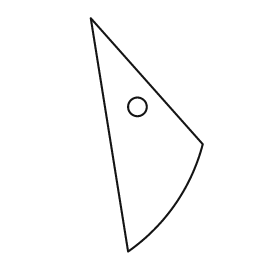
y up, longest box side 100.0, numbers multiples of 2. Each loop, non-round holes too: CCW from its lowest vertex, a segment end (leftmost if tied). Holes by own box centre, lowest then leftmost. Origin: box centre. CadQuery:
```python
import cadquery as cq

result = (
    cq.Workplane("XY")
    .moveTo(-8.0, -50.0)
    .threePointArc((12.0, -30.0), (24.0, -4.0))
    .lineTo(-24.0, 50.0)
    .close()
    .moveTo(-4.0, 12.0)
    .circle(4.0)
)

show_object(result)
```